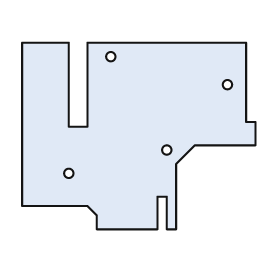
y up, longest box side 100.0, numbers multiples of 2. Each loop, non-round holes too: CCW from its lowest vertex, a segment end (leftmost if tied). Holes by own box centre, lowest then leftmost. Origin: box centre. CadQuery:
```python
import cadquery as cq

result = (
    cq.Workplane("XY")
    .moveTo(-18.0, -40.0)
    .lineTo(8.0, -40.0)
    .lineTo(8.0, -26.0)
    .lineTo(12.0, -26.0)
    .lineTo(12.0, -40.0)
    .lineTo(16.0, -40.0)
    .lineTo(16.0, -12.0)
    .lineTo(24.0, -4.0)
    .lineTo(50.0, -4.0)
    .lineTo(50.0, 6.0)
    .lineTo(46.0, 6.0)
    .lineTo(46.0, 40.0)
    .lineTo(-22.0, 40.0)
    .lineTo(-22.0, 4.0)
    .lineTo(-30.0, 4.0)
    .lineTo(-30.0, 40.0)
    .lineTo(-50.0, 40.0)
    .lineTo(-50.0, -30.0)
    .lineTo(-22.0, -30.0)
    .lineTo(-18.0, -34.0)
    .close()
    .moveTo(-30.0, -16.0)
    .circle(2.0)
    .moveTo(12.0, -6.0)
    .circle(2.0)
    .moveTo(38.0, 22.0)
    .circle(2.0)
    .moveTo(-12.0, 34.0)
    .circle(2.0)
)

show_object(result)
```